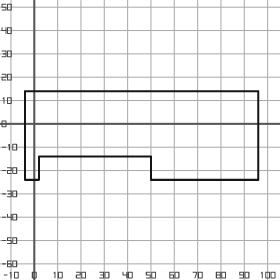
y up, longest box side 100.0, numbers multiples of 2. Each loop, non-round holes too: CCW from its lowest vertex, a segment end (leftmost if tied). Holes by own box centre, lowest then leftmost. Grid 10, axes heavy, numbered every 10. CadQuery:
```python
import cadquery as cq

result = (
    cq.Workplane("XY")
    .moveTo(-4.0, -24.0)
    .lineTo(2.0, -24.0)
    .lineTo(2.0, -14.0)
    .lineTo(50.0, -14.0)
    .lineTo(50.0, -24.0)
    .lineTo(96.0, -24.0)
    .lineTo(96.0, 14.0)
    .lineTo(-4.0, 14.0)
    .close()
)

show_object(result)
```